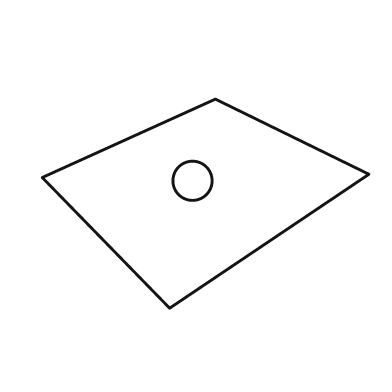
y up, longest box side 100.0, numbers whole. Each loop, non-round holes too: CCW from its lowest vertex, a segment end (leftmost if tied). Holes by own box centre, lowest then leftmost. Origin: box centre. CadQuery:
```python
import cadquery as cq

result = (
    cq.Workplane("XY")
    .moveTo(-11.0, -32.0)
    .lineTo(50.0, 9.0)
    .lineTo(3.0, 32.0)
    .lineTo(-50.0, 8.0)
    .close()
    .moveTo(-4.0, 7.0)
    .circle(6.0)
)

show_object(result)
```